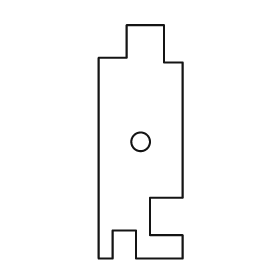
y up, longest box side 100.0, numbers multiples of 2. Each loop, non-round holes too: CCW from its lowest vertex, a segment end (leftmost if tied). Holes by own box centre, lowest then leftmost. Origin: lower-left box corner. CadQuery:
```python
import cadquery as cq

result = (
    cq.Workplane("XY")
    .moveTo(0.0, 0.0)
    .lineTo(6.0, 0.0)
    .lineTo(6.0, 12.0)
    .lineTo(16.0, 12.0)
    .lineTo(16.0, 0.0)
    .lineTo(36.0, 0.0)
    .lineTo(36.0, 10.0)
    .lineTo(22.0, 10.0)
    .lineTo(22.0, 26.0)
    .lineTo(36.0, 26.0)
    .lineTo(36.0, 84.0)
    .lineTo(28.0, 84.0)
    .lineTo(28.0, 100.0)
    .lineTo(12.0, 100.0)
    .lineTo(12.0, 86.0)
    .lineTo(0.0, 86.0)
    .close()
    .moveTo(18.0, 50.0)
    .circle(4.0)
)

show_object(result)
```